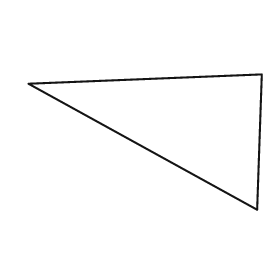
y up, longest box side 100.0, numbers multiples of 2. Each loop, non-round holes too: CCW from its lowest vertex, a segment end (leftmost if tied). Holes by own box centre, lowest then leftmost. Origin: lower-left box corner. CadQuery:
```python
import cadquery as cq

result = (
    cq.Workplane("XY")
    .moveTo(98.0, 0.0)
    .lineTo(100.0, 58.0)
    .lineTo(0.0, 54.0)
    .close()
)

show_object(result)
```